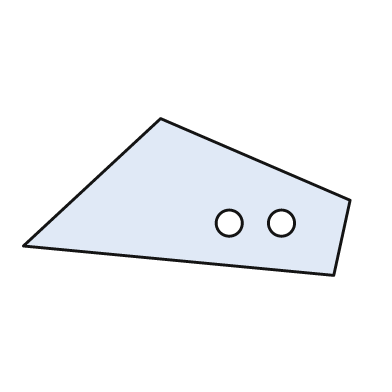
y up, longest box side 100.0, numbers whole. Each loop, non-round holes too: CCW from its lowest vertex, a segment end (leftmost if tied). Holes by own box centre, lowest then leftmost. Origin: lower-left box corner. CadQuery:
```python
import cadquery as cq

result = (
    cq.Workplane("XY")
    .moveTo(95.0, 0.0)
    .lineTo(100.0, 23.0)
    .lineTo(42.0, 48.0)
    .lineTo(0.0, 9.0)
    .close()
    .moveTo(63.0, 16.0)
    .circle(4.0)
    .moveTo(79.0, 16.0)
    .circle(4.0)
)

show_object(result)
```